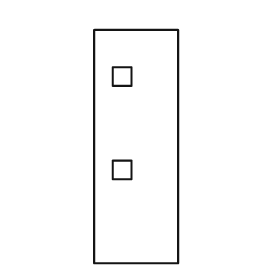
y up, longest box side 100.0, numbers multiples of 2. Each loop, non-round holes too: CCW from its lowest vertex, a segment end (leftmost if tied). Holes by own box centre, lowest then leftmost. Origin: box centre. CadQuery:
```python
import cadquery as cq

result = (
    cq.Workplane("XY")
    .moveTo(-18.0, -50.0)
    .lineTo(18.0, -50.0)
    .lineTo(18.0, 50.0)
    .lineTo(-18.0, 50.0)
    .close()
    .moveTo(-10.0, -14.0)
    .lineTo(-2.0, -14.0)
    .lineTo(-2.0, -6.0)
    .lineTo(-10.0, -6.0)
    .close()
    .moveTo(-10.0, 26.0)
    .lineTo(-2.0, 26.0)
    .lineTo(-2.0, 34.0)
    .lineTo(-10.0, 34.0)
    .close()
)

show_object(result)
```